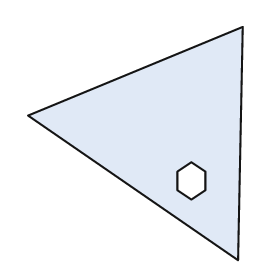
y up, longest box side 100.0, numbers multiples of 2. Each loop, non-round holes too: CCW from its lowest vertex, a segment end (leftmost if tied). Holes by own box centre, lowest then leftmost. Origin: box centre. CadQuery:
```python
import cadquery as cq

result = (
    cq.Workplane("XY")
    .moveTo(44.0, -50.0)
    .lineTo(46.0, 50.0)
    .lineTo(-46.0, 12.0)
    .close()
    .moveTo(24.0, -24.0)
    .lineTo(30.0, -20.0)
    .lineTo(30.0, -12.0)
    .lineTo(24.0, -8.0)
    .lineTo(18.0, -12.0)
    .lineTo(18.0, -20.0)
    .close()
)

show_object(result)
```